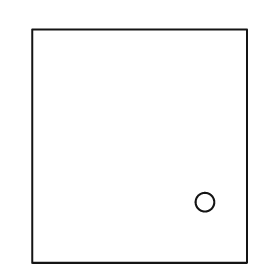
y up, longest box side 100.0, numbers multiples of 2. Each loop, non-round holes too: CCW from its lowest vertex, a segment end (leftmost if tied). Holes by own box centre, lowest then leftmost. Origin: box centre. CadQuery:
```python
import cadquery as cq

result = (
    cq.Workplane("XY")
    .moveTo(-46.0, -50.0)
    .lineTo(46.0, -50.0)
    .lineTo(46.0, 50.0)
    .lineTo(-46.0, 50.0)
    .close()
    .moveTo(28.0, -24.0)
    .circle(4.0)
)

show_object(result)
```